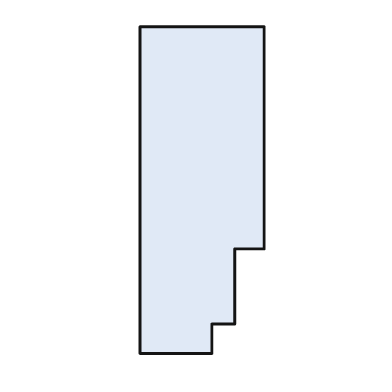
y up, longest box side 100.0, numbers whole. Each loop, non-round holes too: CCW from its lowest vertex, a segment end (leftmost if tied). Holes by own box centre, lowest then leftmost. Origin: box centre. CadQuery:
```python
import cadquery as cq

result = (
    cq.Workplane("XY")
    .moveTo(-19.0, -50.0)
    .lineTo(3.0, -50.0)
    .lineTo(3.0, -41.0)
    .lineTo(10.0, -41.0)
    .lineTo(10.0, -18.0)
    .lineTo(19.0, -18.0)
    .lineTo(19.0, 50.0)
    .lineTo(-19.0, 50.0)
    .close()
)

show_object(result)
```